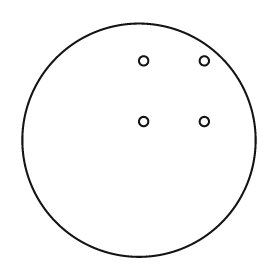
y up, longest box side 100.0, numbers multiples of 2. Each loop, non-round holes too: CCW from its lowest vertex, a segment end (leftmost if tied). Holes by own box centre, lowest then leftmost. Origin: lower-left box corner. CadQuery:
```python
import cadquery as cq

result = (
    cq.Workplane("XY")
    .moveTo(50.0, 50.0)
    .circle(50.0)
    .moveTo(52.0, 58.0)
    .circle(2.0)
    .moveTo(78.0, 58.0)
    .circle(2.0)
    .moveTo(52.0, 84.0)
    .circle(2.0)
    .moveTo(78.0, 84.0)
    .circle(2.0)
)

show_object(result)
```